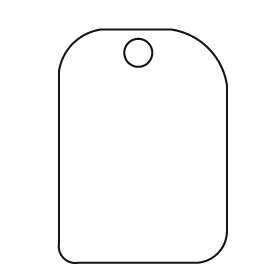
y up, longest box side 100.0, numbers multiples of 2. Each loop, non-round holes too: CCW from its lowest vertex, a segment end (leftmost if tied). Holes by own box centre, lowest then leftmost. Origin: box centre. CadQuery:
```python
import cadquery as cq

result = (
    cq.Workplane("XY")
    .moveTo(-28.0, -50.0)
    .lineTo(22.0, -50.0)
    .threePointArc((32.0, -46.0), (36.0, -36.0))
    .lineTo(36.0, 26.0)
    .threePointArc((28.0, 42.0), (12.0, 50.0))
    .lineTo(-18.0, 50.0)
    .threePointArc((-30.0, 44.0), (-36.0, 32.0))
    .lineTo(-36.0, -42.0)
    .threePointArc((-34.0, -48.0), (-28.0, -50.0))
    .close()
    .moveTo(-2.0, 40.0)
    .circle(6.0)
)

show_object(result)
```